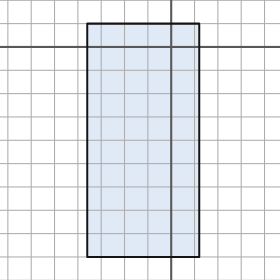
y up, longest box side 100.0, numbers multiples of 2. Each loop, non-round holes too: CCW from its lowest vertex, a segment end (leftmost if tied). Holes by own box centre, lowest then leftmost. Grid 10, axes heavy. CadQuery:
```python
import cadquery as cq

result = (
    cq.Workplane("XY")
    .moveTo(-36.0, -90.0)
    .lineTo(12.0, -90.0)
    .lineTo(12.0, 10.0)
    .lineTo(-36.0, 10.0)
    .close()
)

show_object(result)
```